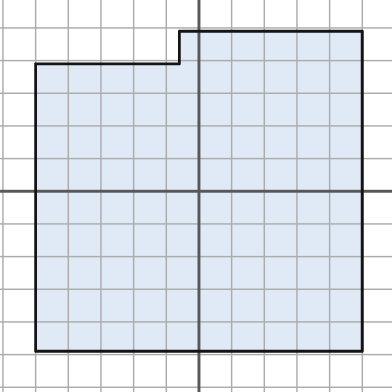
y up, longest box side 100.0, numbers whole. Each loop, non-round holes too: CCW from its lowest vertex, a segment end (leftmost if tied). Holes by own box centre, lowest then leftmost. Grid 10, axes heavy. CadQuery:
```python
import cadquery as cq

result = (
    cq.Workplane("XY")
    .moveTo(-50.0, -49.0)
    .lineTo(50.0, -49.0)
    .lineTo(50.0, 49.0)
    .lineTo(-6.0, 49.0)
    .lineTo(-6.0, 39.0)
    .lineTo(-50.0, 39.0)
    .close()
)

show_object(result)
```